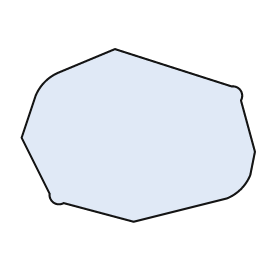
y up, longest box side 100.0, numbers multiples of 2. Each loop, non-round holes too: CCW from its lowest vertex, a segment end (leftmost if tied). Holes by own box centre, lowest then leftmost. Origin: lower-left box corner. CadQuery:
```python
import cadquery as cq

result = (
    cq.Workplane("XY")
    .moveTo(48.0, 0.0)
    .lineTo(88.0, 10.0)
    .threePointArc((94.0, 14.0), (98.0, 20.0))
    .lineTo(100.0, 30.0)
    .lineTo(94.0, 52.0)
    .threePointArc((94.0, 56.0), (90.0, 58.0))
    .lineTo(40.0, 74.0)
    .lineTo(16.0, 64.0)
    .threePointArc((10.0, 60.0), (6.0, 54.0))
    .lineTo(0.0, 36.0)
    .lineTo(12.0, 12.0)
    .threePointArc((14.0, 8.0), (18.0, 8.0))
    .close()
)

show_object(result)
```